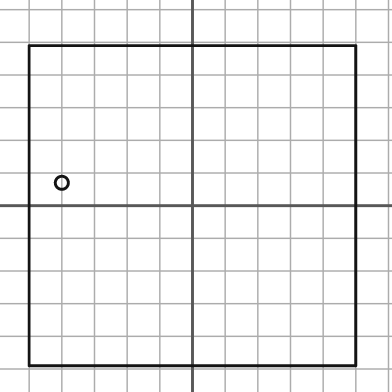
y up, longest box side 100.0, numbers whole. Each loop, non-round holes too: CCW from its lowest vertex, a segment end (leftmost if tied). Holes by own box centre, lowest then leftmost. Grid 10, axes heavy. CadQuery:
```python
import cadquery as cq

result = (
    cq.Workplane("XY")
    .moveTo(-50.0, -49.0)
    .lineTo(50.0, -49.0)
    .lineTo(50.0, 49.0)
    .lineTo(-50.0, 49.0)
    .close()
    .moveTo(-40.0, 7.0)
    .circle(2.0)
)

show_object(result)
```